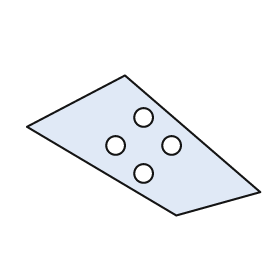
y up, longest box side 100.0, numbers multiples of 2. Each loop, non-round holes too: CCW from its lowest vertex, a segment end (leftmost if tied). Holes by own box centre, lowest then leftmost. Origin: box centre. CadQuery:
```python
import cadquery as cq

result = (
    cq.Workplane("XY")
    .moveTo(14.0, -30.0)
    .lineTo(50.0, -20.0)
    .lineTo(-8.0, 30.0)
    .lineTo(-50.0, 8.0)
    .close()
    .moveTo(0.0, -12.0)
    .circle(4.0)
    .moveTo(-12.0, 0.0)
    .circle(4.0)
    .moveTo(12.0, 0.0)
    .circle(4.0)
    .moveTo(0.0, 12.0)
    .circle(4.0)
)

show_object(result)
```